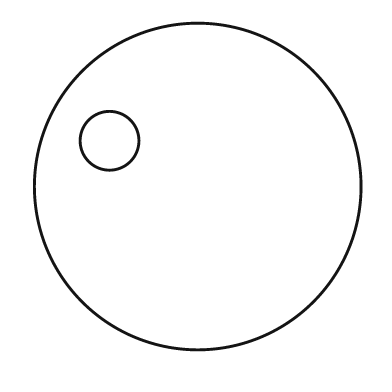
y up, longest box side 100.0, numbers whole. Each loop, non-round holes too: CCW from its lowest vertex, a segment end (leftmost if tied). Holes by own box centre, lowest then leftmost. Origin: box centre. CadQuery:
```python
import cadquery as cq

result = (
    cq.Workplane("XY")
    .moveTo(0.0, 0.0)
    .circle(50.0)
    .moveTo(-27.0, 14.0)
    .circle(9.0)
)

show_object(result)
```